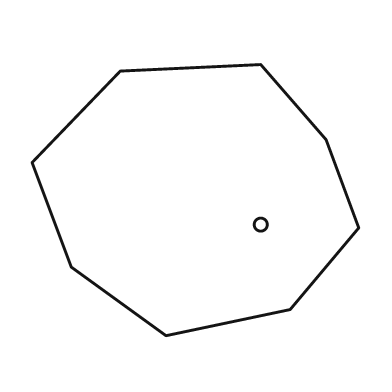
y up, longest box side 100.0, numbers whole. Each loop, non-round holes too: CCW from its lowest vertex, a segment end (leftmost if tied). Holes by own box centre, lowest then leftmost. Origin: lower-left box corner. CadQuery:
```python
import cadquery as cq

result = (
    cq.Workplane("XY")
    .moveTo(41.0, 0.0)
    .lineTo(79.0, 8.0)
    .lineTo(100.0, 33.0)
    .lineTo(90.0, 60.0)
    .lineTo(70.0, 83.0)
    .lineTo(27.0, 81.0)
    .lineTo(0.0, 53.0)
    .lineTo(12.0, 21.0)
    .close()
    .moveTo(70.0, 34.0)
    .circle(2.0)
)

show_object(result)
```